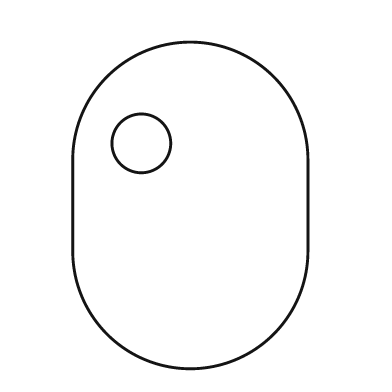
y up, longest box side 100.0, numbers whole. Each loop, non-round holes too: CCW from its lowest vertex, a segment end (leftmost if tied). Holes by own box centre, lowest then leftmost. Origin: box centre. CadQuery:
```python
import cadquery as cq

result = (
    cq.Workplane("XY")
    .moveTo(-36.0, -14.0)
    .threePointArc((0.0, -50.0), (36.0, -14.0))
    .lineTo(36.0, 14.0)
    .threePointArc((0.0, 50.0), (-36.0, 14.0))
    .close()
    .moveTo(-15.0, 19.0)
    .circle(9.0)
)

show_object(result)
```